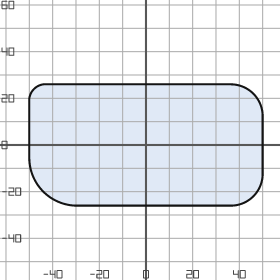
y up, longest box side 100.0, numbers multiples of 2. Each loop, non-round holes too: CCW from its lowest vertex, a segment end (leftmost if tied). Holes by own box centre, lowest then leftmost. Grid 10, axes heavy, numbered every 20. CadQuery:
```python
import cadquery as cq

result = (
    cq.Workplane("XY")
    .moveTo(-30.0, -26.0)
    .lineTo(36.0, -26.0)
    .threePointArc((46.0, -22.0), (50.0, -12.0))
    .lineTo(50.0, 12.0)
    .threePointArc((46.0, 22.0), (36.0, 26.0))
    .lineTo(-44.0, 26.0)
    .threePointArc((-48.0, 24.0), (-50.0, 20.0))
    .lineTo(-50.0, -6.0)
    .threePointArc((-44.0, -20.0), (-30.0, -26.0))
    .close()
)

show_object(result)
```